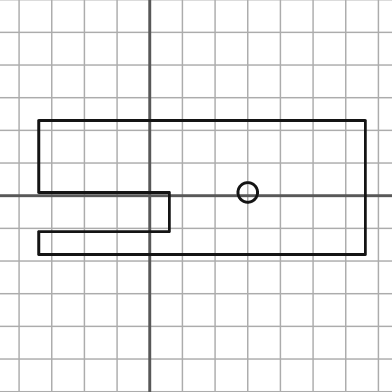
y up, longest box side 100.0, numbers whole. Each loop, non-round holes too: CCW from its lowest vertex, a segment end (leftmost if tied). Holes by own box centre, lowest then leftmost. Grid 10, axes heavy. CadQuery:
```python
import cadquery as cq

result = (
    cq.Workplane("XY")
    .moveTo(-34.0, -18.0)
    .lineTo(66.0, -18.0)
    .lineTo(66.0, 23.0)
    .lineTo(-34.0, 23.0)
    .lineTo(-34.0, 1.0)
    .lineTo(6.0, 1.0)
    .lineTo(6.0, -11.0)
    .lineTo(-34.0, -11.0)
    .close()
    .moveTo(30.0, 1.0)
    .circle(3.0)
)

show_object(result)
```